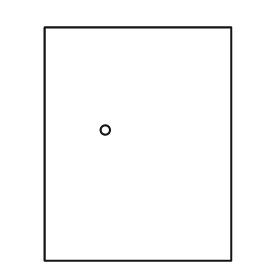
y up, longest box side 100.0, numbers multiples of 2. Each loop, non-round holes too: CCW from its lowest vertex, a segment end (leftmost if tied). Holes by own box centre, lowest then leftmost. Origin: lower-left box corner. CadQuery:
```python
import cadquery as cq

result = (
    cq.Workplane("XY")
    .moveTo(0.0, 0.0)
    .lineTo(80.0, 0.0)
    .lineTo(80.0, 100.0)
    .lineTo(0.0, 100.0)
    .close()
    .moveTo(26.0, 56.0)
    .circle(2.0)
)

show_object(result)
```